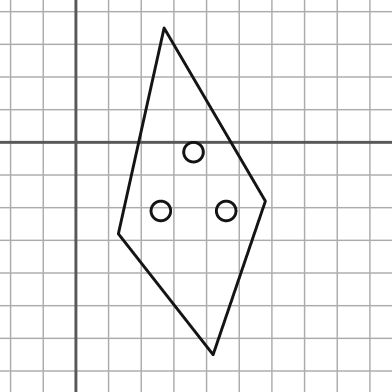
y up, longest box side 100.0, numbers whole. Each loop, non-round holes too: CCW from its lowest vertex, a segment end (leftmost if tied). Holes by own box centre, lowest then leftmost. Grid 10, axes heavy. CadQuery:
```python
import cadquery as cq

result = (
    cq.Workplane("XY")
    .moveTo(42.0, -65.0)
    .lineTo(58.0, -18.0)
    .lineTo(27.0, 35.0)
    .lineTo(13.0, -28.0)
    .close()
    .moveTo(26.0, -21.0)
    .circle(3.0)
    .moveTo(46.0, -21.0)
    .circle(3.0)
    .moveTo(36.0, -3.0)
    .circle(3.0)
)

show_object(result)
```